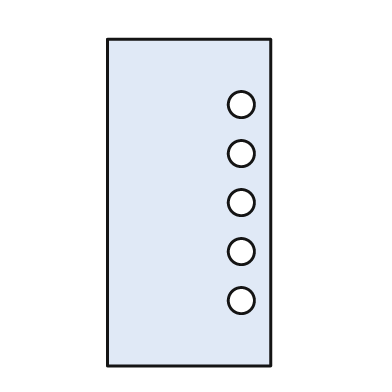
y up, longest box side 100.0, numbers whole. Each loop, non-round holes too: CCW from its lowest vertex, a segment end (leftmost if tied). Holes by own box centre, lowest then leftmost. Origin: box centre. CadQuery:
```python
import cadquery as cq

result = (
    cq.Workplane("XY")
    .moveTo(-25.0, -50.0)
    .lineTo(25.0, -50.0)
    .lineTo(25.0, 50.0)
    .lineTo(-25.0, 50.0)
    .close()
    .moveTo(16.0, -30.0)
    .circle(4.0)
    .moveTo(16.0, -15.0)
    .circle(4.0)
    .moveTo(16.0, 0.0)
    .circle(4.0)
    .moveTo(16.0, 15.0)
    .circle(4.0)
    .moveTo(16.0, 30.0)
    .circle(4.0)
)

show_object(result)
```